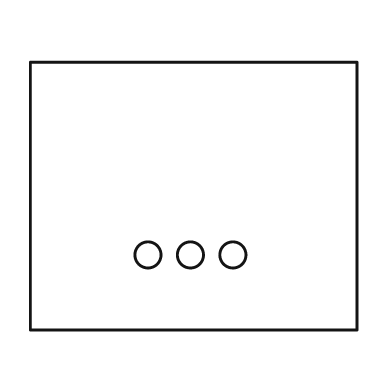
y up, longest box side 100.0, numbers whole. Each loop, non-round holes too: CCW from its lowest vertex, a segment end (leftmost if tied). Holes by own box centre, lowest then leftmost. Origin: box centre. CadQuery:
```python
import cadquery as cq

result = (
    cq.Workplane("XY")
    .moveTo(-50.0, -41.0)
    .lineTo(50.0, -41.0)
    .lineTo(50.0, 41.0)
    .lineTo(-50.0, 41.0)
    .close()
    .moveTo(-14.0, -18.0)
    .circle(4.0)
    .moveTo(-1.0, -18.0)
    .circle(4.0)
    .moveTo(12.0, -18.0)
    .circle(4.0)
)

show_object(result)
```